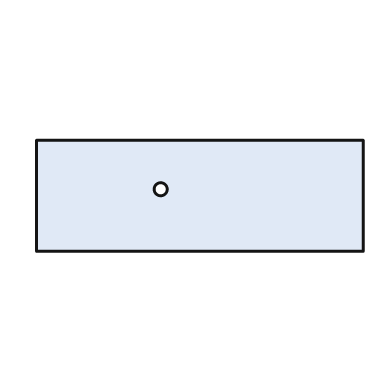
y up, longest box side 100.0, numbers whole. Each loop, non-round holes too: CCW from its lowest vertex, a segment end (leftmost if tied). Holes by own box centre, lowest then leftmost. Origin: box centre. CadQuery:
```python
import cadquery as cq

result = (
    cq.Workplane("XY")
    .moveTo(-50.0, -17.0)
    .lineTo(50.0, -17.0)
    .lineTo(50.0, 17.0)
    .lineTo(-50.0, 17.0)
    .close()
    .moveTo(-12.0, 2.0)
    .circle(2.0)
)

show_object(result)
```